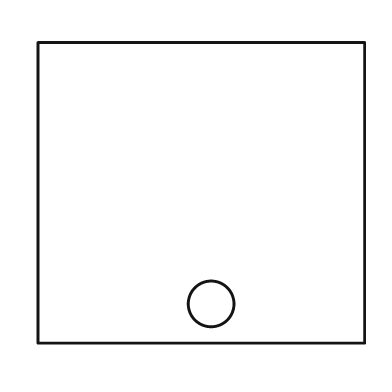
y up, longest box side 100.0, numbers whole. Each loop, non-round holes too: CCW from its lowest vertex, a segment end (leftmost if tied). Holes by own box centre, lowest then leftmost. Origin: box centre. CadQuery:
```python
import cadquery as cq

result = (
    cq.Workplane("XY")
    .moveTo(-50.0, -46.0)
    .lineTo(50.0, -46.0)
    .lineTo(50.0, 46.0)
    .lineTo(-50.0, 46.0)
    .close()
    .moveTo(3.0, -34.0)
    .circle(7.0)
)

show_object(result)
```